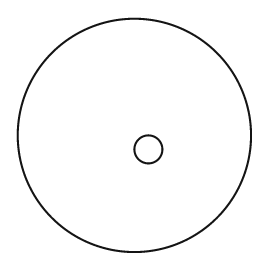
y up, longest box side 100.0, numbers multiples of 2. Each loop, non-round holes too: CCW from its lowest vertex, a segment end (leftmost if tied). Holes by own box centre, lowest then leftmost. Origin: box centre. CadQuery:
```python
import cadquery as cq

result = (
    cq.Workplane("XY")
    .moveTo(0.0, 0.0)
    .circle(50.0)
    .moveTo(6.0, -6.0)
    .circle(6.0)
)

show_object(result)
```